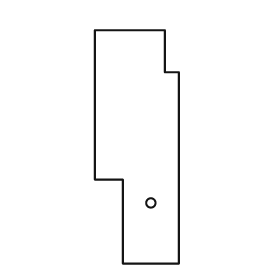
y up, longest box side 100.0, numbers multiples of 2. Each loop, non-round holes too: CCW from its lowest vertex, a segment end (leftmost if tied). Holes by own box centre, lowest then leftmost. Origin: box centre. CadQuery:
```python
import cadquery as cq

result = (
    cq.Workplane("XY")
    .moveTo(-6.0, -50.0)
    .lineTo(18.0, -50.0)
    .lineTo(18.0, 32.0)
    .lineTo(12.0, 32.0)
    .lineTo(12.0, 50.0)
    .lineTo(-18.0, 50.0)
    .lineTo(-18.0, -14.0)
    .lineTo(-6.0, -14.0)
    .close()
    .moveTo(6.0, -24.0)
    .circle(2.0)
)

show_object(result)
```